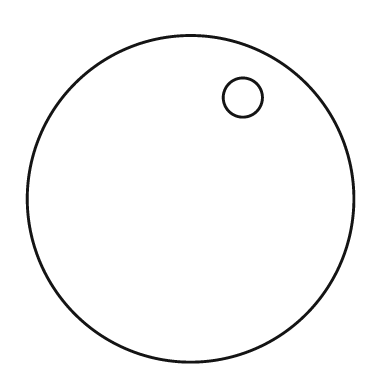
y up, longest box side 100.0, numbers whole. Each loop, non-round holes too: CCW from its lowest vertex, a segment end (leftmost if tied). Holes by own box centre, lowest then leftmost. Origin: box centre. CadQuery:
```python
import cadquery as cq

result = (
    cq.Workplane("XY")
    .moveTo(0.0, 0.0)
    .circle(50.0)
    .moveTo(16.0, 31.0)
    .circle(6.0)
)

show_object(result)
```